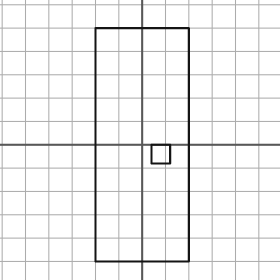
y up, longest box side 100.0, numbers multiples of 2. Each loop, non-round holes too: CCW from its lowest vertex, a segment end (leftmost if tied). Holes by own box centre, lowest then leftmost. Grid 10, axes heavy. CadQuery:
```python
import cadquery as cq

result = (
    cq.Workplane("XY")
    .moveTo(-20.0, -50.0)
    .lineTo(20.0, -50.0)
    .lineTo(20.0, 50.0)
    .lineTo(-20.0, 50.0)
    .close()
    .moveTo(4.0, -8.0)
    .lineTo(12.0, -8.0)
    .lineTo(12.0, 0.0)
    .lineTo(4.0, 0.0)
    .close()
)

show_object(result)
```